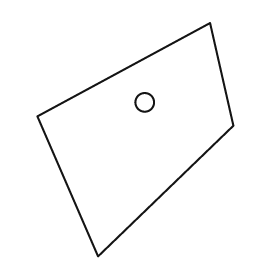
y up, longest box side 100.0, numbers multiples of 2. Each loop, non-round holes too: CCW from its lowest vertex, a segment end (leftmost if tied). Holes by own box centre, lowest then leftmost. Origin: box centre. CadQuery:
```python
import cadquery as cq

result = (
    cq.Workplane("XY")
    .moveTo(-16.0, -50.0)
    .lineTo(42.0, 6.0)
    .lineTo(32.0, 50.0)
    .lineTo(-42.0, 10.0)
    .close()
    .moveTo(4.0, 16.0)
    .circle(4.0)
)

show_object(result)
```